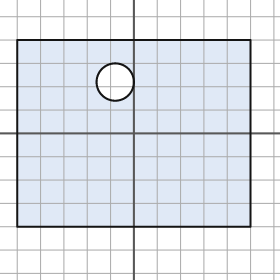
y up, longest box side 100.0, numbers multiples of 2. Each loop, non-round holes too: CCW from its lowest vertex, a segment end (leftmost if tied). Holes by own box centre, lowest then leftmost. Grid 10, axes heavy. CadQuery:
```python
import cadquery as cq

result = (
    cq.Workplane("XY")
    .moveTo(-50.0, -40.0)
    .lineTo(50.0, -40.0)
    .lineTo(50.0, 40.0)
    .lineTo(-50.0, 40.0)
    .close()
    .moveTo(-8.0, 22.0)
    .circle(8.0)
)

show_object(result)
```